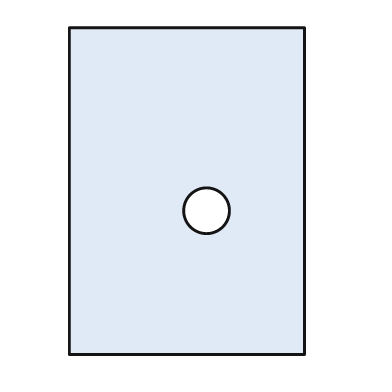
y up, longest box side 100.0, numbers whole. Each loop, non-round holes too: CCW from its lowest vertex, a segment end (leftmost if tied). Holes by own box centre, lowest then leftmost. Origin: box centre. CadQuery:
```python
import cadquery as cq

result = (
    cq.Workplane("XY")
    .moveTo(-36.0, -50.0)
    .lineTo(36.0, -50.0)
    .lineTo(36.0, 50.0)
    .lineTo(-36.0, 50.0)
    .close()
    .moveTo(6.0, -6.0)
    .circle(7.0)
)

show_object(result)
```